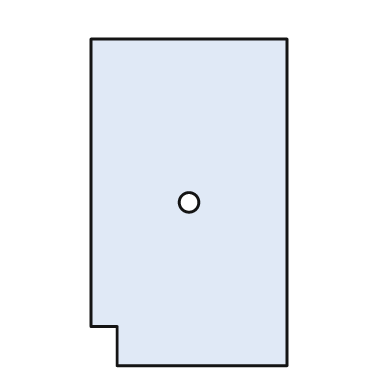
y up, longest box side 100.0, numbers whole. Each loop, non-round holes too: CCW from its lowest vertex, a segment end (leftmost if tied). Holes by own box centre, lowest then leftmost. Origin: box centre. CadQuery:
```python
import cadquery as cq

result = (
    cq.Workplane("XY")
    .moveTo(-22.0, -50.0)
    .lineTo(30.0, -50.0)
    .lineTo(30.0, 50.0)
    .lineTo(-30.0, 50.0)
    .lineTo(-30.0, -38.0)
    .lineTo(-22.0, -38.0)
    .close()
    .moveTo(0.0, 0.0)
    .circle(3.0)
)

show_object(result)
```